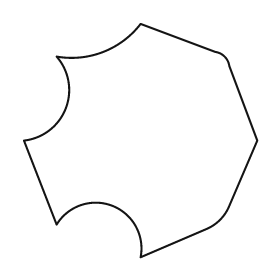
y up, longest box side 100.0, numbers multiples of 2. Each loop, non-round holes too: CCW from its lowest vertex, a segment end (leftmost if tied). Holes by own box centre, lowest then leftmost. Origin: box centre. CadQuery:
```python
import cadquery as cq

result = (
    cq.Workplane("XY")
    .moveTo(0.0, -50.0)
    .lineTo(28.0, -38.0)
    .threePointArc((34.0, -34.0), (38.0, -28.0))
    .lineTo(50.0, 0.0)
    .lineTo(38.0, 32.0)
    .threePointArc((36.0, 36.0), (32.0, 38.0))
    .lineTo(0.0, 50.0)
    .threePointArc((-16.0, 38.0), (-36.0, 36.0))
    .threePointArc((-32.0, 14.0), (-50.0, 0.0))
    .lineTo(-36.0, -36.0)
    .threePointArc((-12.0, -28.0), (0.0, -50.0))
    .close()
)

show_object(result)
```